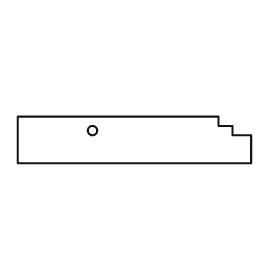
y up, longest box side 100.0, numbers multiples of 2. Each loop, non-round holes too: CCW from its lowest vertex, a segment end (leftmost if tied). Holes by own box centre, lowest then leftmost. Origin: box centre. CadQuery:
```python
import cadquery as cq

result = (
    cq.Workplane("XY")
    .moveTo(-50.0, -10.0)
    .lineTo(50.0, -10.0)
    .lineTo(50.0, 2.0)
    .lineTo(42.0, 2.0)
    .lineTo(42.0, 6.0)
    .lineTo(36.0, 6.0)
    .lineTo(36.0, 10.0)
    .lineTo(-50.0, 10.0)
    .close()
    .moveTo(-18.0, 4.0)
    .circle(2.0)
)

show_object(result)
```